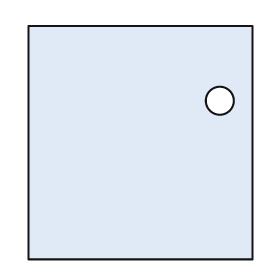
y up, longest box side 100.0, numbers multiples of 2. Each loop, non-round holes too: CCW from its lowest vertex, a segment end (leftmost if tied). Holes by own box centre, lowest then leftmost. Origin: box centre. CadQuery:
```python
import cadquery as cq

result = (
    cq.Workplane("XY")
    .moveTo(-48.0, -50.0)
    .lineTo(48.0, -50.0)
    .lineTo(48.0, 50.0)
    .lineTo(-48.0, 50.0)
    .close()
    .moveTo(34.0, 18.0)
    .circle(6.0)
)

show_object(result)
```